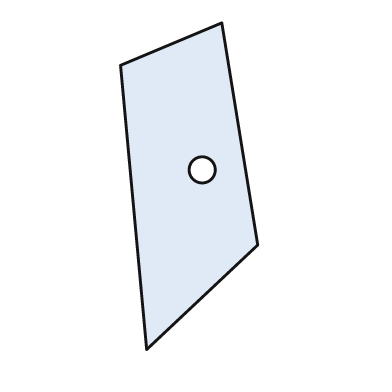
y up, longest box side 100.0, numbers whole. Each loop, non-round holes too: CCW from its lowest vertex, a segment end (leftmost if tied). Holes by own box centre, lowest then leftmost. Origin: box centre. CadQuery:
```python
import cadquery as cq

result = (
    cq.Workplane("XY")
    .moveTo(-13.0, -50.0)
    .lineTo(21.0, -18.0)
    .lineTo(10.0, 50.0)
    .lineTo(-21.0, 37.0)
    .close()
    .moveTo(4.0, 5.0)
    .circle(4.0)
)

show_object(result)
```